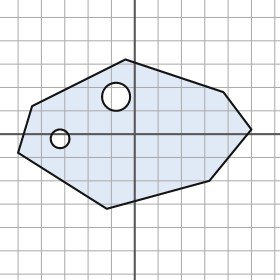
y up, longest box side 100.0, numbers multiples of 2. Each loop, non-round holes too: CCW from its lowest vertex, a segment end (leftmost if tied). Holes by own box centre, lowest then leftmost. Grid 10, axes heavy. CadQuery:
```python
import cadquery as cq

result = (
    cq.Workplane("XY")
    .moveTo(-12.0, -32.0)
    .lineTo(32.0, -20.0)
    .lineTo(50.0, 2.0)
    .lineTo(38.0, 18.0)
    .lineTo(-4.0, 32.0)
    .lineTo(-44.0, 12.0)
    .lineTo(-50.0, -8.0)
    .close()
    .moveTo(-32.0, -2.0)
    .circle(4.0)
    .moveTo(-8.0, 16.0)
    .circle(6.0)
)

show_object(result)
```